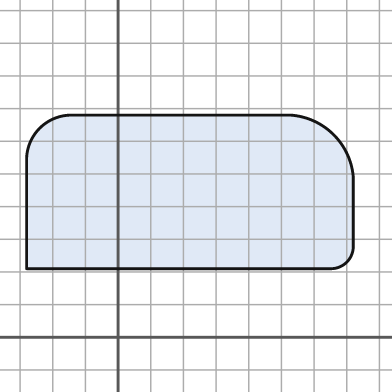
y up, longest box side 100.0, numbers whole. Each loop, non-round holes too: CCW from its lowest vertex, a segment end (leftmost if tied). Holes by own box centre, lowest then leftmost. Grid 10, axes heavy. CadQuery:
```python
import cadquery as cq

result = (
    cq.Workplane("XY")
    .moveTo(-28.0, 21.0)
    .lineTo(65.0, 21.0)
    .threePointArc((70.0, 23.0), (72.0, 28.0))
    .lineTo(72.0, 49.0)
    .threePointArc((66.0, 62.0), (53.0, 68.0))
    .lineTo(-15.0, 68.0)
    .threePointArc((-24.0, 64.0), (-28.0, 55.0))
    .close()
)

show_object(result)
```